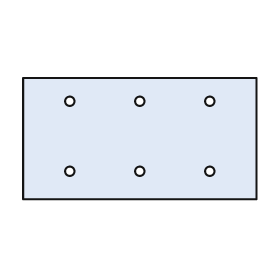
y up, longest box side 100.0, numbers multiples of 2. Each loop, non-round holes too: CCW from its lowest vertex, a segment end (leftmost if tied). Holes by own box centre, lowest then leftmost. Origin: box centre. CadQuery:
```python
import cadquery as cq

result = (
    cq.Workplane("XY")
    .moveTo(-50.0, -26.0)
    .lineTo(50.0, -26.0)
    .lineTo(50.0, 26.0)
    .lineTo(-50.0, 26.0)
    .close()
    .moveTo(-30.0, -14.0)
    .circle(2.0)
    .moveTo(0.0, -14.0)
    .circle(2.0)
    .moveTo(30.0, -14.0)
    .circle(2.0)
    .moveTo(-30.0, 16.0)
    .circle(2.0)
    .moveTo(0.0, 16.0)
    .circle(2.0)
    .moveTo(30.0, 16.0)
    .circle(2.0)
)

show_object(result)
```